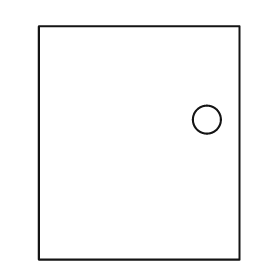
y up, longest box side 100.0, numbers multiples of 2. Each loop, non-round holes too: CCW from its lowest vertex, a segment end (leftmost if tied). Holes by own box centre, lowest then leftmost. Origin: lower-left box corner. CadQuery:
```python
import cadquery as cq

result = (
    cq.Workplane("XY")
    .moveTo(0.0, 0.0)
    .lineTo(86.0, 0.0)
    .lineTo(86.0, 100.0)
    .lineTo(0.0, 100.0)
    .close()
    .moveTo(72.0, 60.0)
    .circle(6.0)
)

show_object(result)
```